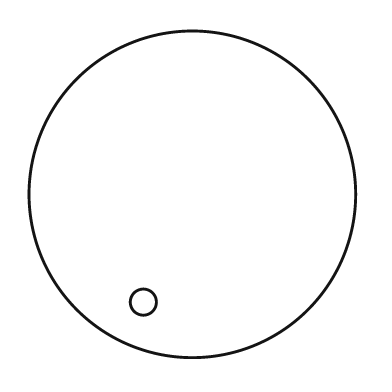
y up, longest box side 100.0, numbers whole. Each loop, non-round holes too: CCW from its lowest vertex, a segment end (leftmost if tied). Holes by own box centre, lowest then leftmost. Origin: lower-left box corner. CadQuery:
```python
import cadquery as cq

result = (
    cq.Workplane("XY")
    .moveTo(50.0, 50.0)
    .circle(50.0)
    .moveTo(35.0, 17.0)
    .circle(4.0)
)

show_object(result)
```